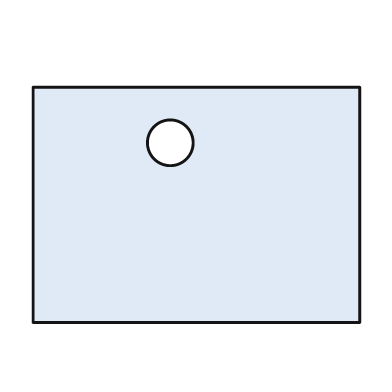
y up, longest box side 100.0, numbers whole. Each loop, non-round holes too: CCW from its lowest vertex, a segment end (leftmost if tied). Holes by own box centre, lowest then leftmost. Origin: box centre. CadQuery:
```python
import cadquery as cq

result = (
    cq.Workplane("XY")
    .moveTo(-50.0, -36.0)
    .lineTo(50.0, -36.0)
    .lineTo(50.0, 36.0)
    .lineTo(-50.0, 36.0)
    .close()
    .moveTo(-8.0, 19.0)
    .circle(7.0)
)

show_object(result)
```